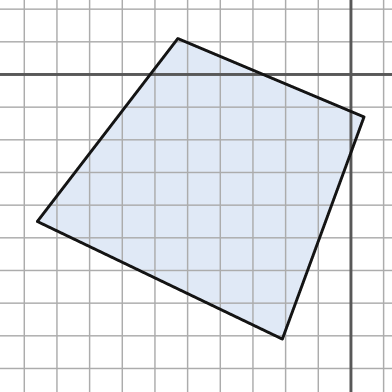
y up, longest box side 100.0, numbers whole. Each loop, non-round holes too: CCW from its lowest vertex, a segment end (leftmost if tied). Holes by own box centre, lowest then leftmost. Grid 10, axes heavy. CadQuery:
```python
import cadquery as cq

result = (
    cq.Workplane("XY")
    .moveTo(-21.0, -81.0)
    .lineTo(4.0, -13.0)
    .lineTo(-53.0, 11.0)
    .lineTo(-96.0, -45.0)
    .close()
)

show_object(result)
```